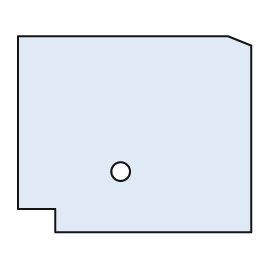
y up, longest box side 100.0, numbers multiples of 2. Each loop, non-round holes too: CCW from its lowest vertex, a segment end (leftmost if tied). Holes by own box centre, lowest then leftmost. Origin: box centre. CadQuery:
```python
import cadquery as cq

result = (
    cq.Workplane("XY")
    .moveTo(-34.0, -42.0)
    .lineTo(50.0, -42.0)
    .lineTo(50.0, 38.0)
    .lineTo(40.0, 42.0)
    .lineTo(-50.0, 42.0)
    .lineTo(-50.0, -32.0)
    .lineTo(-34.0, -32.0)
    .close()
    .moveTo(-6.0, -16.0)
    .circle(4.0)
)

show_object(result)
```